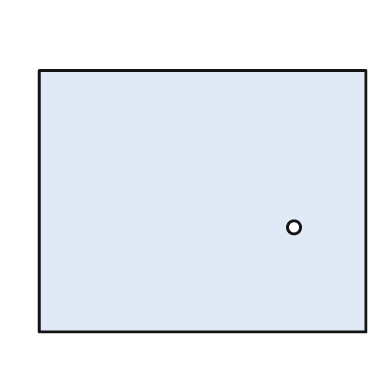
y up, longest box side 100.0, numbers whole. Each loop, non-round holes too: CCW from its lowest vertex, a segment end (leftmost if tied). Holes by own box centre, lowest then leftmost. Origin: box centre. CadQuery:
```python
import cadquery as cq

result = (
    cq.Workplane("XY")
    .moveTo(-50.0, -40.0)
    .lineTo(50.0, -40.0)
    .lineTo(50.0, 40.0)
    .lineTo(-50.0, 40.0)
    .close()
    .moveTo(28.0, -8.0)
    .circle(2.0)
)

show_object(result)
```